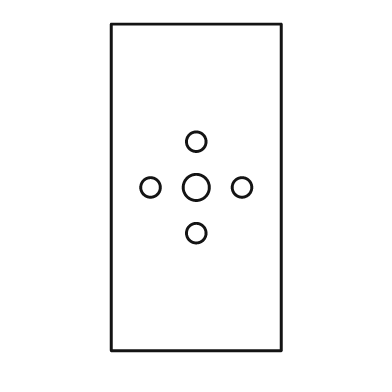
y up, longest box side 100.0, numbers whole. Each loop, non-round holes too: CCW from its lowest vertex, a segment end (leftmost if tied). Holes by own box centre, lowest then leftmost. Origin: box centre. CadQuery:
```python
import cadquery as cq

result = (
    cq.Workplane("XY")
    .moveTo(-26.0, -50.0)
    .lineTo(26.0, -50.0)
    .lineTo(26.0, 50.0)
    .lineTo(-26.0, 50.0)
    .close()
    .moveTo(0.0, -14.0)
    .circle(3.0)
    .moveTo(-14.0, 0.0)
    .circle(3.0)
    .moveTo(0.0, 0.0)
    .circle(4.0)
    .moveTo(14.0, 0.0)
    .circle(3.0)
    .moveTo(0.0, 14.0)
    .circle(3.0)
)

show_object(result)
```